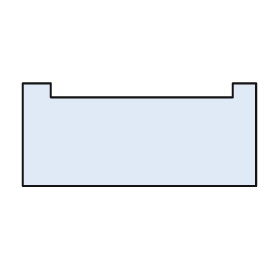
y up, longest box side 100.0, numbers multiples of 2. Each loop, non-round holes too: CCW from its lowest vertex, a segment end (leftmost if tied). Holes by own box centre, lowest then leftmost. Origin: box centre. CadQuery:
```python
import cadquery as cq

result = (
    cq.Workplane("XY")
    .moveTo(-50.0, -22.0)
    .lineTo(50.0, -22.0)
    .lineTo(50.0, 22.0)
    .lineTo(40.0, 22.0)
    .lineTo(40.0, 16.0)
    .lineTo(-38.0, 16.0)
    .lineTo(-38.0, 22.0)
    .lineTo(-50.0, 22.0)
    .close()
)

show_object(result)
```